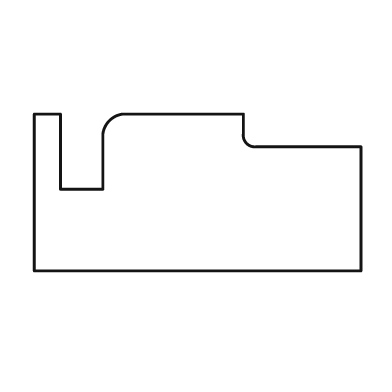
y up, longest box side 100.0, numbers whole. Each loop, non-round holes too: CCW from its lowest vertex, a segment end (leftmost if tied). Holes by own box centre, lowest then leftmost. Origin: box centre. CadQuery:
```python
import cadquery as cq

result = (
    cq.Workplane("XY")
    .moveTo(-50.0, -24.0)
    .lineTo(50.0, -24.0)
    .lineTo(50.0, 14.0)
    .lineTo(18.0, 14.0)
    .threePointArc((15.0, 15.0), (14.0, 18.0))
    .lineTo(14.0, 24.0)
    .lineTo(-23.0, 24.0)
    .threePointArc((-27.0, 22.0), (-29.0, 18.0))
    .lineTo(-29.0, 1.0)
    .lineTo(-42.0, 1.0)
    .lineTo(-42.0, 24.0)
    .lineTo(-50.0, 24.0)
    .close()
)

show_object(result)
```